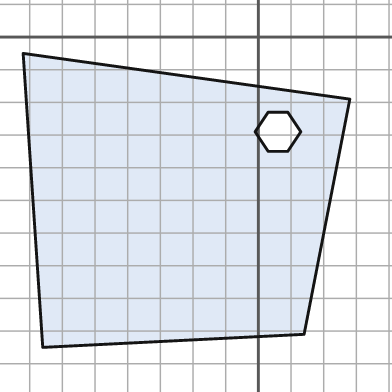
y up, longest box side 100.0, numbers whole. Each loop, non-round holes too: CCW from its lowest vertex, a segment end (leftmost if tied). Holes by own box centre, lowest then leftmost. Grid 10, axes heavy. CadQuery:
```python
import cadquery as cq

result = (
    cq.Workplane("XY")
    .moveTo(-66.0, -95.0)
    .lineTo(14.0, -91.0)
    .lineTo(28.0, -19.0)
    .lineTo(-72.0, -5.0)
    .close()
    .moveTo(3.0, -35.0)
    .lineTo(9.0, -35.0)
    .lineTo(13.0, -29.0)
    .lineTo(9.0, -23.0)
    .lineTo(3.0, -23.0)
    .lineTo(-1.0, -29.0)
    .close()
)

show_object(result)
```